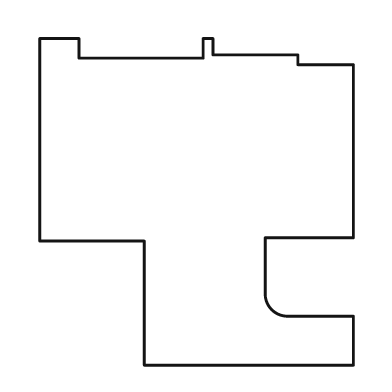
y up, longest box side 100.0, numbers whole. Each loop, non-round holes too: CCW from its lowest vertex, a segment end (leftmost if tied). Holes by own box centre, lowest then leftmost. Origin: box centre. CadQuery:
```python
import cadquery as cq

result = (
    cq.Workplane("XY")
    .moveTo(-16.0, -50.0)
    .lineTo(48.0, -50.0)
    .lineTo(48.0, -35.0)
    .lineTo(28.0, -35.0)
    .threePointArc((23.0, -33.0), (21.0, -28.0))
    .lineTo(21.0, -11.0)
    .lineTo(48.0, -11.0)
    .lineTo(48.0, 42.0)
    .lineTo(31.0, 42.0)
    .lineTo(31.0, 45.0)
    .lineTo(5.0, 45.0)
    .lineTo(5.0, 50.0)
    .lineTo(2.0, 50.0)
    .lineTo(2.0, 44.0)
    .lineTo(-36.0, 44.0)
    .lineTo(-36.0, 50.0)
    .lineTo(-48.0, 50.0)
    .lineTo(-48.0, -12.0)
    .lineTo(-16.0, -12.0)
    .close()
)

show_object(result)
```